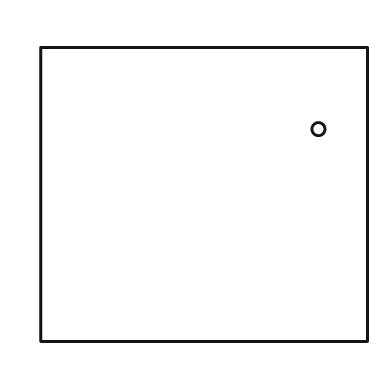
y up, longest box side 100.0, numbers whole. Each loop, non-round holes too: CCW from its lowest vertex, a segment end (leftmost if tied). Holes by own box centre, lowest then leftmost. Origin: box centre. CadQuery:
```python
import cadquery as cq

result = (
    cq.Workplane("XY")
    .moveTo(-50.0, -45.0)
    .lineTo(50.0, -45.0)
    .lineTo(50.0, 45.0)
    .lineTo(-50.0, 45.0)
    .close()
    .moveTo(35.0, 20.0)
    .circle(2.0)
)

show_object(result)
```